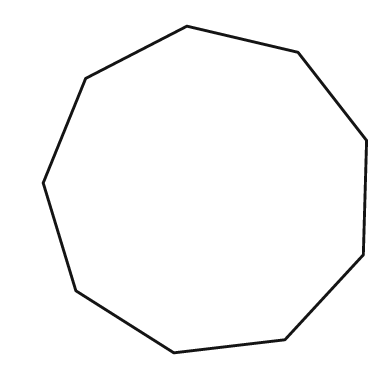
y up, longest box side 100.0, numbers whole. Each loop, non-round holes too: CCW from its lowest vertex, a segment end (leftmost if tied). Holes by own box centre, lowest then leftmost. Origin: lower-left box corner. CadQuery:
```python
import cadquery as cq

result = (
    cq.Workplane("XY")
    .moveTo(40.0, 0.0)
    .lineTo(74.0, 4.0)
    .lineTo(98.0, 30.0)
    .lineTo(99.0, 65.0)
    .lineTo(78.0, 92.0)
    .lineTo(44.0, 100.0)
    .lineTo(13.0, 84.0)
    .lineTo(0.0, 52.0)
    .lineTo(10.0, 19.0)
    .close()
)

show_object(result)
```